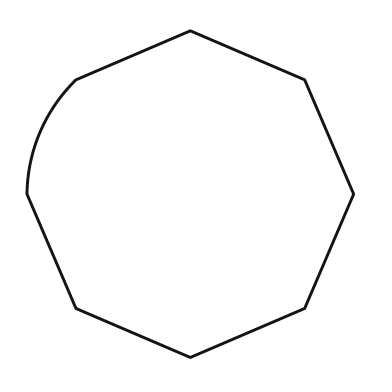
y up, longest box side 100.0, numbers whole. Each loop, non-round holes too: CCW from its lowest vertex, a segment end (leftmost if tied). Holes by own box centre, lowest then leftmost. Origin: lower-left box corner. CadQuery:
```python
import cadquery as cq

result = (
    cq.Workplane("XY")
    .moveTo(50.0, 0.0)
    .lineTo(85.0, 15.0)
    .lineTo(100.0, 50.0)
    .lineTo(85.0, 85.0)
    .lineTo(50.0, 100.0)
    .lineTo(15.0, 85.0)
    .threePointArc((4.0, 69.0), (0.0, 50.0))
    .lineTo(15.0, 15.0)
    .close()
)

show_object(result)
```